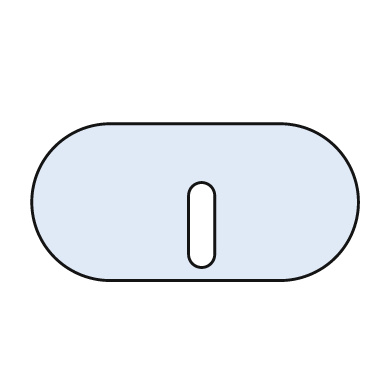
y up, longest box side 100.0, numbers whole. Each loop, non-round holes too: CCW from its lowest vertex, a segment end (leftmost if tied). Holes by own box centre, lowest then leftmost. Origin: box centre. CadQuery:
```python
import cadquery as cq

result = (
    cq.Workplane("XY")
    .moveTo(-26.0, -24.0)
    .lineTo(26.0, -24.0)
    .threePointArc((50.0, 0.0), (26.0, 24.0))
    .lineTo(-26.0, 24.0)
    .threePointArc((-50.0, 0.0), (-26.0, -24.0))
    .close()
    .moveTo(-2.0, -16.0)
    .threePointArc((2.0, -20.0), (6.0, -16.0))
    .lineTo(6.0, 2.0)
    .threePointArc((2.0, 6.0), (-2.0, 2.0))
    .close()
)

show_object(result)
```